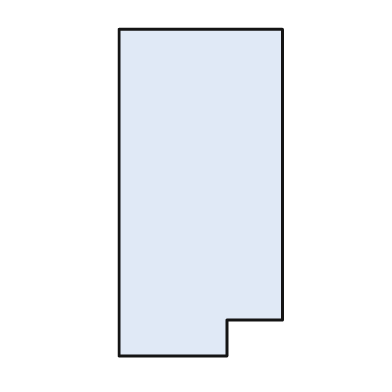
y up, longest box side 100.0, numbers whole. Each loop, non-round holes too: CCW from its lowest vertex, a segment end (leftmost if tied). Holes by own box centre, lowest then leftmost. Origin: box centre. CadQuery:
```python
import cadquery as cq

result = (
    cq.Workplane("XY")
    .moveTo(-25.0, -50.0)
    .lineTo(8.0, -50.0)
    .lineTo(8.0, -39.0)
    .lineTo(25.0, -39.0)
    .lineTo(25.0, 50.0)
    .lineTo(-25.0, 50.0)
    .close()
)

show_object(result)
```